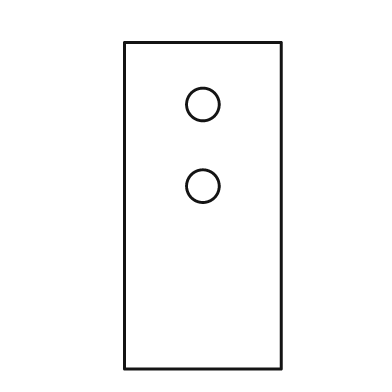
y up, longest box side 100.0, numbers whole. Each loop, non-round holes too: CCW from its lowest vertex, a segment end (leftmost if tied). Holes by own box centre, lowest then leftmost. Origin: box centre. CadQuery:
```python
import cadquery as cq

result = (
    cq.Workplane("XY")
    .moveTo(-24.0, -50.0)
    .lineTo(24.0, -50.0)
    .lineTo(24.0, 50.0)
    .lineTo(-24.0, 50.0)
    .close()
    .moveTo(0.0, 6.0)
    .circle(5.0)
    .moveTo(0.0, 31.0)
    .circle(5.0)
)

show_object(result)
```